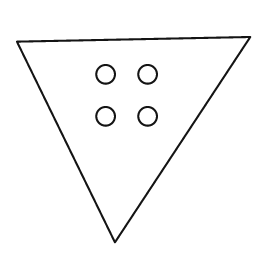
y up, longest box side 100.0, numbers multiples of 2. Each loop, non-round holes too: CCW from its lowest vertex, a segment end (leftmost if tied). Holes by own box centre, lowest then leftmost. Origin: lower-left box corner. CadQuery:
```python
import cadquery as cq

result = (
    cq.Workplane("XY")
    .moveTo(42.0, 0.0)
    .lineTo(100.0, 88.0)
    .lineTo(0.0, 86.0)
    .close()
    .moveTo(38.0, 54.0)
    .circle(4.0)
    .moveTo(56.0, 54.0)
    .circle(4.0)
    .moveTo(38.0, 72.0)
    .circle(4.0)
    .moveTo(56.0, 72.0)
    .circle(4.0)
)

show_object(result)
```